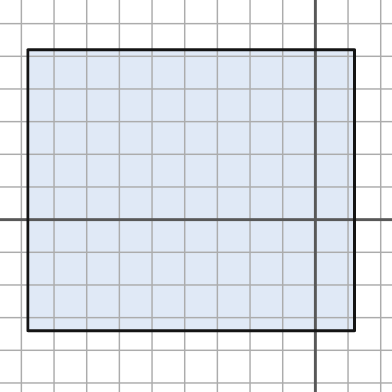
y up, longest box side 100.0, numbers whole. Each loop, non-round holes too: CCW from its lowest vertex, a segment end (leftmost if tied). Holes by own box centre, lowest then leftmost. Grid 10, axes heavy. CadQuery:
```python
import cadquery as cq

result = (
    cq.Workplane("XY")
    .moveTo(-88.0, -34.0)
    .lineTo(12.0, -34.0)
    .lineTo(12.0, 52.0)
    .lineTo(-88.0, 52.0)
    .close()
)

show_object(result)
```